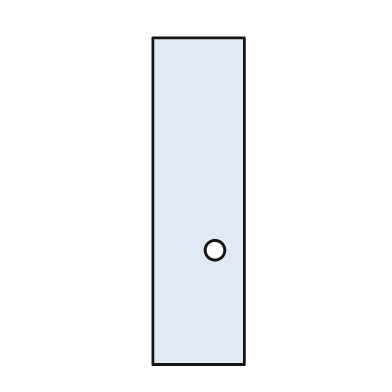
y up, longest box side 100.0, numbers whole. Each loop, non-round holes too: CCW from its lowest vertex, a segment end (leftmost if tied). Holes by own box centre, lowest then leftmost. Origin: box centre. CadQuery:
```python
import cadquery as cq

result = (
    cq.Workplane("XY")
    .moveTo(-14.0, -50.0)
    .lineTo(14.0, -50.0)
    .lineTo(14.0, 50.0)
    .lineTo(-14.0, 50.0)
    .close()
    .moveTo(5.0, -15.0)
    .circle(3.0)
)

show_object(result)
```